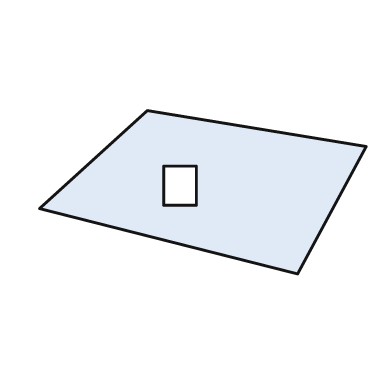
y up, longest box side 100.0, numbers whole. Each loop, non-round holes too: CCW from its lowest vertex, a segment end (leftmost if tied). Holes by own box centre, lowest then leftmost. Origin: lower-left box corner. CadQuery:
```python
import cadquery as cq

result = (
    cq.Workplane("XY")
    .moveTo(79.0, 0.0)
    .lineTo(100.0, 39.0)
    .lineTo(33.0, 50.0)
    .lineTo(0.0, 20.0)
    .close()
    .moveTo(38.0, 21.0)
    .lineTo(48.0, 21.0)
    .lineTo(48.0, 33.0)
    .lineTo(38.0, 33.0)
    .close()
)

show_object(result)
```